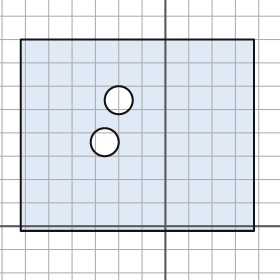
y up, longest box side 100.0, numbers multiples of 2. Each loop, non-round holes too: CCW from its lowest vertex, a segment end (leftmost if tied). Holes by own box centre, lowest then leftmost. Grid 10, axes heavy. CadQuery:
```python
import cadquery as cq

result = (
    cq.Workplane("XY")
    .moveTo(-62.0, -2.0)
    .lineTo(38.0, -2.0)
    .lineTo(38.0, 80.0)
    .lineTo(-62.0, 80.0)
    .close()
    .moveTo(-26.0, 36.0)
    .circle(6.0)
    .moveTo(-20.0, 54.0)
    .circle(6.0)
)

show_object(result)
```